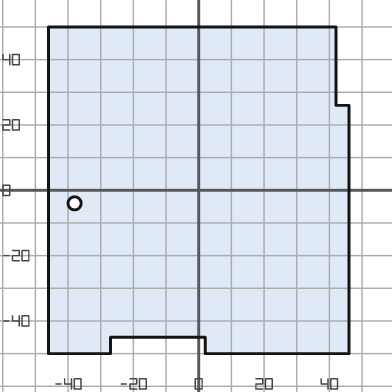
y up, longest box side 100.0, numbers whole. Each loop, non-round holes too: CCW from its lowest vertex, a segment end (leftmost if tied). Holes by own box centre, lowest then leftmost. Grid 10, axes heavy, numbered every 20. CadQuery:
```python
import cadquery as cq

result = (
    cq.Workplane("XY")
    .moveTo(-46.0, -50.0)
    .lineTo(-27.0, -50.0)
    .lineTo(-27.0, -45.0)
    .lineTo(2.0, -45.0)
    .lineTo(2.0, -50.0)
    .lineTo(46.0, -50.0)
    .lineTo(46.0, 26.0)
    .lineTo(42.0, 26.0)
    .lineTo(42.0, 50.0)
    .lineTo(-46.0, 50.0)
    .close()
    .moveTo(-38.0, -4.0)
    .circle(2.0)
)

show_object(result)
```